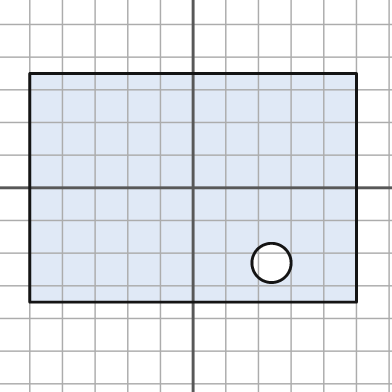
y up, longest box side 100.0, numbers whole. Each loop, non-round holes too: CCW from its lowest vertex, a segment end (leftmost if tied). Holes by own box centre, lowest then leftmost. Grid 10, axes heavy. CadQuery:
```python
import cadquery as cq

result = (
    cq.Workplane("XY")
    .moveTo(-50.0, -35.0)
    .lineTo(50.0, -35.0)
    .lineTo(50.0, 35.0)
    .lineTo(-50.0, 35.0)
    .close()
    .moveTo(24.0, -23.0)
    .circle(6.0)
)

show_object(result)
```